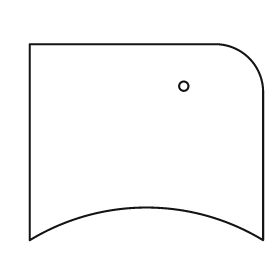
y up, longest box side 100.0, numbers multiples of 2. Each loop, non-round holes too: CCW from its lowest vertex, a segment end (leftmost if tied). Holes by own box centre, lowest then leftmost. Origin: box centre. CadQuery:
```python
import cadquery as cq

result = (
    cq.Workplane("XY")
    .moveTo(-50.0, -42.0)
    .threePointArc((0.0, -28.0), (50.0, -42.0))
    .lineTo(50.0, 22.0)
    .threePointArc((44.0, 36.0), (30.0, 42.0))
    .lineTo(-50.0, 42.0)
    .close()
    .moveTo(16.0, 24.0)
    .circle(2.0)
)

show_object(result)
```